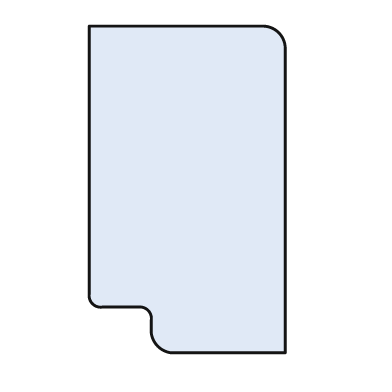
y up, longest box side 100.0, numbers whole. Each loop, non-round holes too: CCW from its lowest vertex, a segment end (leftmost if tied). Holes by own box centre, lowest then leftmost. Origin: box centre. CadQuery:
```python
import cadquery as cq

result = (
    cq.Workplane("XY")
    .moveTo(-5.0, -50.0)
    .lineTo(30.0, -50.0)
    .lineTo(30.0, 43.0)
    .threePointArc((28.0, 48.0), (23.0, 50.0))
    .lineTo(-30.0, 50.0)
    .lineTo(-30.0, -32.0)
    .threePointArc((-29.0, -35.0), (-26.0, -36.0))
    .lineTo(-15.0, -36.0)
    .threePointArc((-12.0, -37.0), (-11.0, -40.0))
    .lineTo(-11.0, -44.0)
    .threePointArc((-9.0, -48.0), (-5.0, -50.0))
    .close()
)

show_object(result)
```